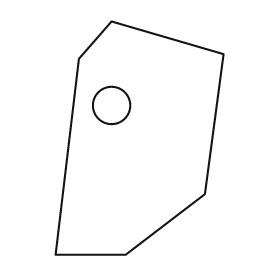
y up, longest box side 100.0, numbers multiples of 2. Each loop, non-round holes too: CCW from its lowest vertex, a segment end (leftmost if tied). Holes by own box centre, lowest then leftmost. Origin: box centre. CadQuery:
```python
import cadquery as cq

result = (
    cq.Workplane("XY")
    .moveTo(-36.0, -50.0)
    .lineTo(-6.0, -50.0)
    .lineTo(28.0, -24.0)
    .lineTo(36.0, 36.0)
    .lineTo(-12.0, 50.0)
    .lineTo(-26.0, 34.0)
    .close()
    .moveTo(-12.0, 14.0)
    .circle(8.0)
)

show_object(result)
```